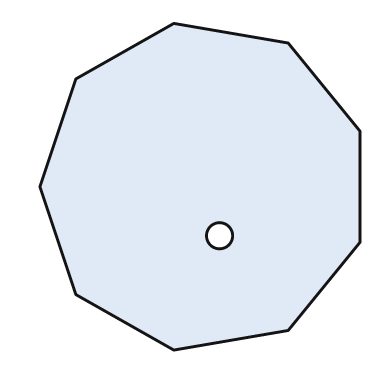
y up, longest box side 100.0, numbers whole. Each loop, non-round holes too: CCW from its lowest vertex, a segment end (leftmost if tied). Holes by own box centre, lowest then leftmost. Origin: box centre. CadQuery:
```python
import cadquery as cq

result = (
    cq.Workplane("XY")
    .moveTo(-8.0, -50.0)
    .lineTo(27.0, -44.0)
    .lineTo(49.0, -17.0)
    .lineTo(49.0, 17.0)
    .lineTo(27.0, 44.0)
    .lineTo(-8.0, 50.0)
    .lineTo(-38.0, 33.0)
    .lineTo(-49.0, 0.0)
    .lineTo(-38.0, -33.0)
    .close()
    .moveTo(6.0, -15.0)
    .circle(4.0)
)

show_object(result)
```